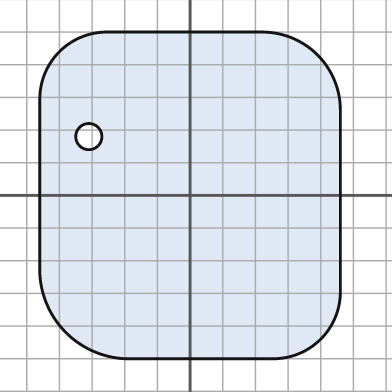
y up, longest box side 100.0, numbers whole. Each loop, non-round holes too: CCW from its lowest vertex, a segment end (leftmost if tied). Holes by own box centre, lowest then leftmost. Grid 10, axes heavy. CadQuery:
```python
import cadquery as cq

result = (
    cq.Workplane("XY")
    .moveTo(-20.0, -50.0)
    .lineTo(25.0, -50.0)
    .threePointArc((40.0, -44.0), (46.0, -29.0))
    .lineTo(46.0, 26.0)
    .threePointArc((39.0, 43.0), (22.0, 50.0))
    .lineTo(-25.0, 50.0)
    .threePointArc((-40.0, 44.0), (-46.0, 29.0))
    .lineTo(-46.0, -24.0)
    .threePointArc((-38.0, -42.0), (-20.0, -50.0))
    .close()
    .moveTo(-31.0, 18.0)
    .circle(4.0)
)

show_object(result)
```